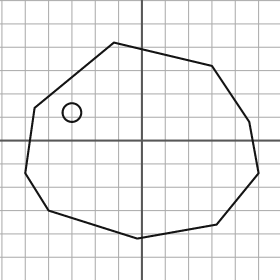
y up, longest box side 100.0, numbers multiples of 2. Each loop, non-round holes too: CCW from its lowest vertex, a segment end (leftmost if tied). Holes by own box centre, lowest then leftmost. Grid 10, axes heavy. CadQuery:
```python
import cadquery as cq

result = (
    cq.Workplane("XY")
    .moveTo(-2.0, -42.0)
    .lineTo(32.0, -36.0)
    .lineTo(50.0, -14.0)
    .lineTo(46.0, 8.0)
    .lineTo(30.0, 32.0)
    .lineTo(-12.0, 42.0)
    .lineTo(-46.0, 14.0)
    .lineTo(-50.0, -14.0)
    .lineTo(-40.0, -30.0)
    .close()
    .moveTo(-30.0, 12.0)
    .circle(4.0)
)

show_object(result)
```